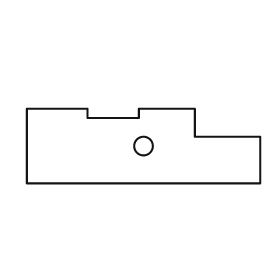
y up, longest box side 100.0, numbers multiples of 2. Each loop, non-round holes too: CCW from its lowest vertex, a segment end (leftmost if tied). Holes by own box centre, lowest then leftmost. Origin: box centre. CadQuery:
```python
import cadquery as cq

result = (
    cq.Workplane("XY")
    .moveTo(-50.0, -16.0)
    .lineTo(50.0, -16.0)
    .lineTo(50.0, 4.0)
    .lineTo(22.0, 4.0)
    .lineTo(22.0, 16.0)
    .lineTo(-2.0, 16.0)
    .lineTo(-2.0, 12.0)
    .lineTo(-24.0, 12.0)
    .lineTo(-24.0, 16.0)
    .lineTo(-50.0, 16.0)
    .close()
    .moveTo(0.0, 0.0)
    .circle(4.0)
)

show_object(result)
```